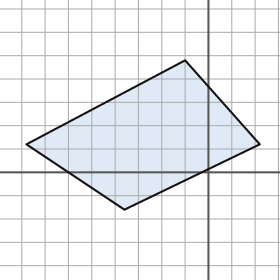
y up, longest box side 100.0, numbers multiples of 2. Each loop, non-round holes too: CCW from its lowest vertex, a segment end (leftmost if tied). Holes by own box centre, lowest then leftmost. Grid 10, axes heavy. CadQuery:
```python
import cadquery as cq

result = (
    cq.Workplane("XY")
    .moveTo(-36.0, -16.0)
    .lineTo(22.0, 12.0)
    .lineTo(-10.0, 48.0)
    .lineTo(-78.0, 12.0)
    .close()
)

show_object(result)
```